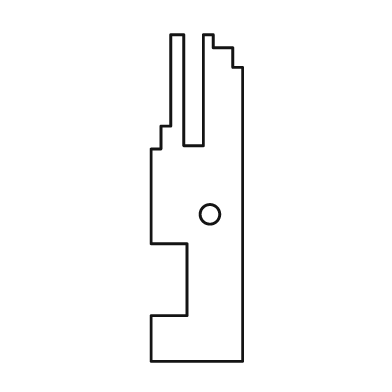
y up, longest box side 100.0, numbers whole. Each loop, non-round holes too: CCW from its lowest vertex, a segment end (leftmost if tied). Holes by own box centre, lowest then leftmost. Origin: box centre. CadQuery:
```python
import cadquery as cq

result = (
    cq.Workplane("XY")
    .moveTo(-14.0, -50.0)
    .lineTo(14.0, -50.0)
    .lineTo(14.0, 40.0)
    .lineTo(11.0, 40.0)
    .lineTo(11.0, 46.0)
    .lineTo(5.0, 46.0)
    .lineTo(5.0, 50.0)
    .lineTo(2.0, 50.0)
    .lineTo(2.0, 16.0)
    .lineTo(-4.0, 16.0)
    .lineTo(-4.0, 50.0)
    .lineTo(-8.0, 50.0)
    .lineTo(-8.0, 22.0)
    .lineTo(-11.0, 22.0)
    .lineTo(-11.0, 15.0)
    .lineTo(-14.0, 15.0)
    .lineTo(-14.0, -14.0)
    .lineTo(-3.0, -14.0)
    .lineTo(-3.0, -36.0)
    .lineTo(-14.0, -36.0)
    .close()
    .moveTo(4.0, -5.0)
    .circle(3.0)
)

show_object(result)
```